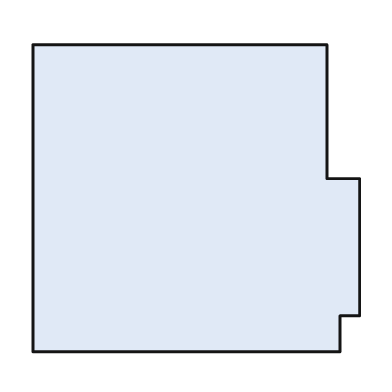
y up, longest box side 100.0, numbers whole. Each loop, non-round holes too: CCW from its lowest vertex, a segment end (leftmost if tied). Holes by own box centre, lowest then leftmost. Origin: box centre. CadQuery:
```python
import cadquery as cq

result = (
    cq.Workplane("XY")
    .moveTo(-50.0, -47.0)
    .lineTo(44.0, -47.0)
    .lineTo(44.0, -36.0)
    .lineTo(50.0, -36.0)
    .lineTo(50.0, 6.0)
    .lineTo(40.0, 6.0)
    .lineTo(40.0, 47.0)
    .lineTo(-50.0, 47.0)
    .close()
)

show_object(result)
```